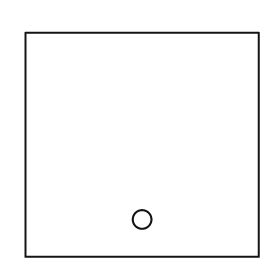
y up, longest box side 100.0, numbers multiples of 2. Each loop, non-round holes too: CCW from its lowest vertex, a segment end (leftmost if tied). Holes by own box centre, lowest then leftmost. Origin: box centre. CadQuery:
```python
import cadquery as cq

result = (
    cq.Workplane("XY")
    .moveTo(-50.0, -48.0)
    .lineTo(50.0, -48.0)
    .lineTo(50.0, 48.0)
    .lineTo(-50.0, 48.0)
    .close()
    .moveTo(0.0, -32.0)
    .circle(4.0)
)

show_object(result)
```